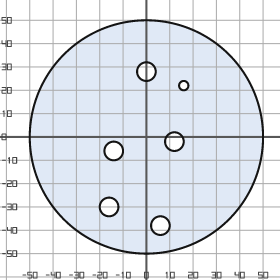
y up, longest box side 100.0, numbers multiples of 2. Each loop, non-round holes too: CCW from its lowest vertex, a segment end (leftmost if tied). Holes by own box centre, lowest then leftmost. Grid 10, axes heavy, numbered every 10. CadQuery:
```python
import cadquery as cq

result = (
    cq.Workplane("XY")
    .moveTo(0.0, 0.0)
    .circle(50.0)
    .moveTo(6.0, -38.0)
    .circle(4.0)
    .moveTo(-16.0, -30.0)
    .circle(4.0)
    .moveTo(-14.0, -6.0)
    .circle(4.0)
    .moveTo(12.0, -2.0)
    .circle(4.0)
    .moveTo(16.0, 22.0)
    .circle(2.0)
    .moveTo(0.0, 28.0)
    .circle(4.0)
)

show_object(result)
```